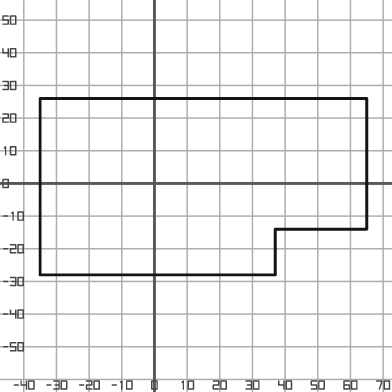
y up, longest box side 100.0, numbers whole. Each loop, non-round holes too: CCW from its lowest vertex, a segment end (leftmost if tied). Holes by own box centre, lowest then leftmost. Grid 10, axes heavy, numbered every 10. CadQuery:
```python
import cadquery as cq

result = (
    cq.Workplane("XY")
    .moveTo(-35.0, -28.0)
    .lineTo(37.0, -28.0)
    .lineTo(37.0, -14.0)
    .lineTo(65.0, -14.0)
    .lineTo(65.0, 26.0)
    .lineTo(-35.0, 26.0)
    .close()
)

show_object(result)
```